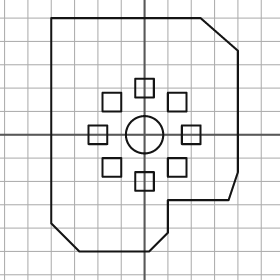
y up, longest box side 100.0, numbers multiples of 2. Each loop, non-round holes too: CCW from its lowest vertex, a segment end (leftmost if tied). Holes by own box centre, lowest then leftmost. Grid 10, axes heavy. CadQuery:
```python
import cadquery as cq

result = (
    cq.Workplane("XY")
    .moveTo(-28.0, -50.0)
    .lineTo(2.0, -50.0)
    .lineTo(10.0, -42.0)
    .lineTo(10.0, -28.0)
    .lineTo(36.0, -28.0)
    .lineTo(40.0, -16.0)
    .lineTo(40.0, 36.0)
    .lineTo(24.0, 50.0)
    .lineTo(-40.0, 50.0)
    .lineTo(-40.0, -38.0)
    .close()
    .moveTo(-4.0, -24.0)
    .lineTo(4.0, -24.0)
    .lineTo(4.0, -16.0)
    .lineTo(-4.0, -16.0)
    .close()
    .moveTo(-18.0, -18.0)
    .lineTo(-10.0, -18.0)
    .lineTo(-10.0, -10.0)
    .lineTo(-18.0, -10.0)
    .close()
    .moveTo(10.0, -18.0)
    .lineTo(18.0, -18.0)
    .lineTo(18.0, -10.0)
    .lineTo(10.0, -10.0)
    .close()
    .moveTo(-24.0, -4.0)
    .lineTo(-16.0, -4.0)
    .lineTo(-16.0, 4.0)
    .lineTo(-24.0, 4.0)
    .close()
    .moveTo(0.0, 0.0)
    .circle(8.0)
    .moveTo(16.0, -4.0)
    .lineTo(24.0, -4.0)
    .lineTo(24.0, 4.0)
    .lineTo(16.0, 4.0)
    .close()
    .moveTo(-18.0, 10.0)
    .lineTo(-10.0, 10.0)
    .lineTo(-10.0, 18.0)
    .lineTo(-18.0, 18.0)
    .close()
    .moveTo(10.0, 10.0)
    .lineTo(18.0, 10.0)
    .lineTo(18.0, 18.0)
    .lineTo(10.0, 18.0)
    .close()
    .moveTo(-4.0, 16.0)
    .lineTo(4.0, 16.0)
    .lineTo(4.0, 24.0)
    .lineTo(-4.0, 24.0)
    .close()
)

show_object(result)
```